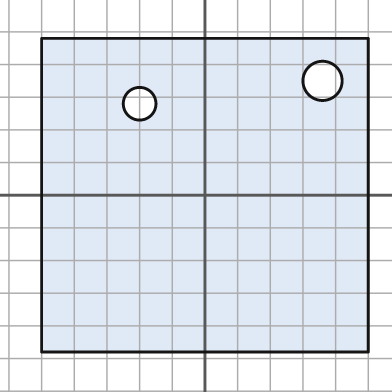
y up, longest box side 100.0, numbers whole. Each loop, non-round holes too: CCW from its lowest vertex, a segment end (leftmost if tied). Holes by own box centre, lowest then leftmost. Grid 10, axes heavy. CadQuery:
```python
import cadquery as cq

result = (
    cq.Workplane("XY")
    .moveTo(-50.0, -48.0)
    .lineTo(50.0, -48.0)
    .lineTo(50.0, 48.0)
    .lineTo(-50.0, 48.0)
    .close()
    .moveTo(-20.0, 28.0)
    .circle(5.0)
    .moveTo(36.0, 35.0)
    .circle(6.0)
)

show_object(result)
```